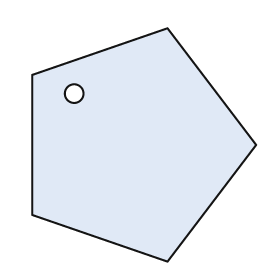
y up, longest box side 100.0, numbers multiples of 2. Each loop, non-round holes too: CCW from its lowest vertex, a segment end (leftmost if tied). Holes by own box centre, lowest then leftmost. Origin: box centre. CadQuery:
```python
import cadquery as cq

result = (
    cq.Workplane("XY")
    .moveTo(10.0, -50.0)
    .lineTo(48.0, 0.0)
    .lineTo(10.0, 50.0)
    .lineTo(-48.0, 30.0)
    .lineTo(-48.0, -30.0)
    .close()
    .moveTo(-30.0, 22.0)
    .circle(4.0)
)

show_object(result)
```